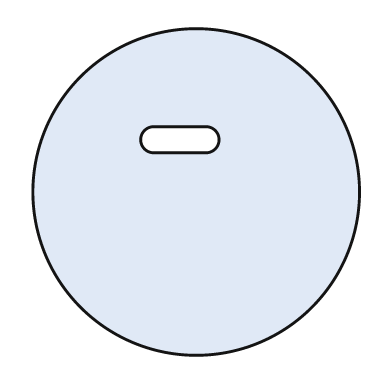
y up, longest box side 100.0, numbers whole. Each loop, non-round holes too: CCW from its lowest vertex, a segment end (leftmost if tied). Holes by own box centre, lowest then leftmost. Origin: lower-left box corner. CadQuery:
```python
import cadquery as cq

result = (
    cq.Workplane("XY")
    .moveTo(50.0, 50.0)
    .circle(50.0)
    .moveTo(37.0, 62.0)
    .lineTo(53.0, 62.0)
    .threePointArc((57.0, 66.0), (53.0, 70.0))
    .lineTo(37.0, 70.0)
    .threePointArc((33.0, 66.0), (37.0, 62.0))
    .close()
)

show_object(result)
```